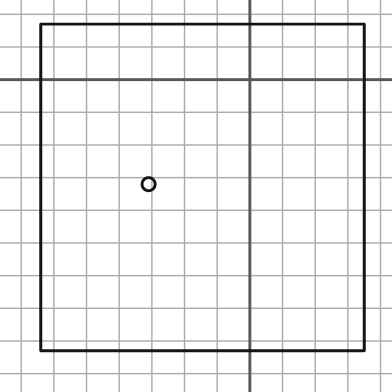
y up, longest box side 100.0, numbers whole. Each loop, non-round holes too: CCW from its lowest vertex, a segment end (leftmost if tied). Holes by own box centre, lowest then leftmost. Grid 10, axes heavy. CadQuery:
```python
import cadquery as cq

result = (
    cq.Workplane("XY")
    .moveTo(-64.0, -83.0)
    .lineTo(35.0, -83.0)
    .lineTo(35.0, 17.0)
    .lineTo(-64.0, 17.0)
    .close()
    .moveTo(-31.0, -32.0)
    .circle(2.0)
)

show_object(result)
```